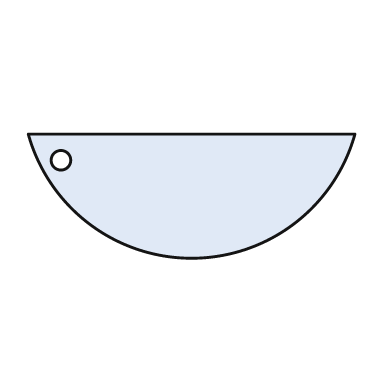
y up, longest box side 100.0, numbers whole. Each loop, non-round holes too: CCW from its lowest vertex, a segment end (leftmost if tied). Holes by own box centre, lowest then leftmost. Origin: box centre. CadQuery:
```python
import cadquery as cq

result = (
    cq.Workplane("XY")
    .moveTo(-50.0, 19.0)
    .threePointArc((0.0, -19.0), (50.0, 19.0))
    .close()
    .moveTo(-40.0, 11.0)
    .circle(3.0)
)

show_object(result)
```